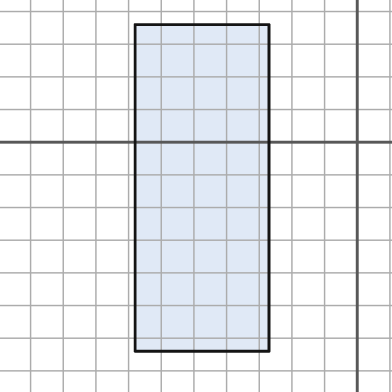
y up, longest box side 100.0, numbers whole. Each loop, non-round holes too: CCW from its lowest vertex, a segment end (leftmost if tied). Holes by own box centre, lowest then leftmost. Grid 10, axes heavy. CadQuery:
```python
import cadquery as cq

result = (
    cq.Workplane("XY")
    .moveTo(-68.0, -64.0)
    .lineTo(-27.0, -64.0)
    .lineTo(-27.0, 36.0)
    .lineTo(-68.0, 36.0)
    .close()
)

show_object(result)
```